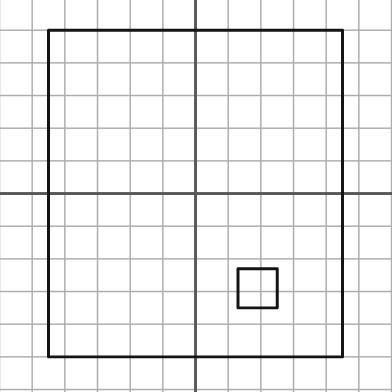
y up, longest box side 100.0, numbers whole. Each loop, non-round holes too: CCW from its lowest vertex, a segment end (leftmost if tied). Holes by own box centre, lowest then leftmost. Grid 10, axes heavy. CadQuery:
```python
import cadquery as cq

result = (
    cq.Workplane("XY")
    .moveTo(-45.0, -50.0)
    .lineTo(45.0, -50.0)
    .lineTo(45.0, 50.0)
    .lineTo(-45.0, 50.0)
    .close()
    .moveTo(13.0, -35.0)
    .lineTo(25.0, -35.0)
    .lineTo(25.0, -23.0)
    .lineTo(13.0, -23.0)
    .close()
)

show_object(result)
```